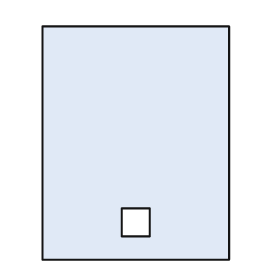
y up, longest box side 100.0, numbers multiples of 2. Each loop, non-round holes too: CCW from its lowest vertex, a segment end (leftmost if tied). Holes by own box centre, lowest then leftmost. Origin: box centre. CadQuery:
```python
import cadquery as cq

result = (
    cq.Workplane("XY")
    .moveTo(-40.0, -50.0)
    .lineTo(40.0, -50.0)
    .lineTo(40.0, 50.0)
    .lineTo(-40.0, 50.0)
    .close()
    .moveTo(-6.0, -40.0)
    .lineTo(6.0, -40.0)
    .lineTo(6.0, -28.0)
    .lineTo(-6.0, -28.0)
    .close()
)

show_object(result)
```